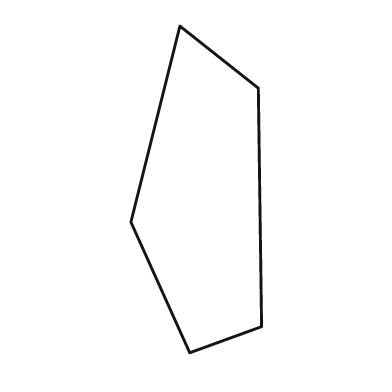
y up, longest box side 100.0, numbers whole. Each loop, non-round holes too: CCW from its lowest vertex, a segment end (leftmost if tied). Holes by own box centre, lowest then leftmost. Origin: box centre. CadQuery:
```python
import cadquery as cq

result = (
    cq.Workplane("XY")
    .moveTo(-2.0, -50.0)
    .lineTo(20.0, -42.0)
    .lineTo(19.0, 31.0)
    .lineTo(-5.0, 50.0)
    .lineTo(-20.0, -10.0)
    .close()
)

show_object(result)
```